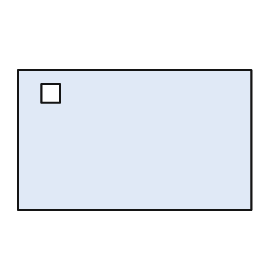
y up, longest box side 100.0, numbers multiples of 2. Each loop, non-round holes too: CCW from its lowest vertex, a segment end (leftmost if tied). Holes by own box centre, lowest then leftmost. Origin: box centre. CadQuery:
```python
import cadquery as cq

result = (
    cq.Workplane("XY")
    .moveTo(-50.0, -30.0)
    .lineTo(50.0, -30.0)
    .lineTo(50.0, 30.0)
    .lineTo(-50.0, 30.0)
    .close()
    .moveTo(-40.0, 16.0)
    .lineTo(-32.0, 16.0)
    .lineTo(-32.0, 24.0)
    .lineTo(-40.0, 24.0)
    .close()
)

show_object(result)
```